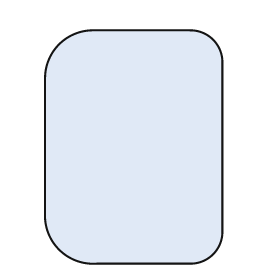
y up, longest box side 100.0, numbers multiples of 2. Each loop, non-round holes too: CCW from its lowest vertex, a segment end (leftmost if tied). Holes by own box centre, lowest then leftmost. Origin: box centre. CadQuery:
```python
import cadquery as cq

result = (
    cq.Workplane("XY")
    .moveTo(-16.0, -50.0)
    .lineTo(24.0, -50.0)
    .threePointArc((34.0, -46.0), (38.0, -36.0))
    .lineTo(38.0, 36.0)
    .threePointArc((34.0, 46.0), (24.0, 50.0))
    .lineTo(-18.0, 50.0)
    .threePointArc((-32.0, 44.0), (-38.0, 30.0))
    .lineTo(-38.0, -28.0)
    .threePointArc((-32.0, -44.0), (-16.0, -50.0))
    .close()
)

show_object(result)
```